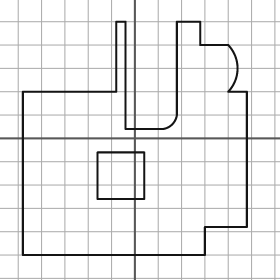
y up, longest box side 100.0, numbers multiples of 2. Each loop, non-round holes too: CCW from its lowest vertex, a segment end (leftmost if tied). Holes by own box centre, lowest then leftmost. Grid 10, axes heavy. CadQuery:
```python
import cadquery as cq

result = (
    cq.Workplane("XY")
    .moveTo(-48.0, -50.0)
    .lineTo(30.0, -50.0)
    .lineTo(30.0, -38.0)
    .lineTo(48.0, -38.0)
    .lineTo(48.0, 20.0)
    .lineTo(40.0, 20.0)
    .threePointArc((44.0, 30.0), (40.0, 40.0))
    .lineTo(28.0, 40.0)
    .lineTo(28.0, 50.0)
    .lineTo(18.0, 50.0)
    .lineTo(18.0, 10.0)
    .threePointArc((16.0, 6.0), (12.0, 4.0))
    .lineTo(-4.0, 4.0)
    .lineTo(-4.0, 50.0)
    .lineTo(-8.0, 50.0)
    .lineTo(-8.0, 20.0)
    .lineTo(-48.0, 20.0)
    .close()
    .moveTo(-16.0, -26.0)
    .lineTo(4.0, -26.0)
    .lineTo(4.0, -6.0)
    .lineTo(-16.0, -6.0)
    .close()
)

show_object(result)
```